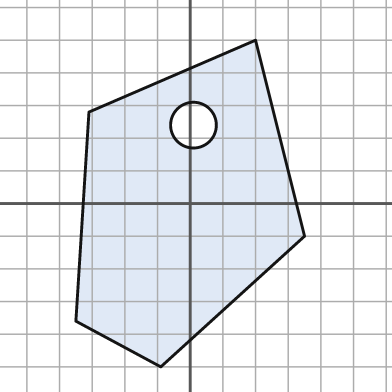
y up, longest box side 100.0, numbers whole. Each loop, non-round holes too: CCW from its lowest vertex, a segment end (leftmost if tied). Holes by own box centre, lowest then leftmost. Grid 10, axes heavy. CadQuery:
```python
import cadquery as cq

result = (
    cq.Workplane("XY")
    .moveTo(-9.0, -50.0)
    .lineTo(35.0, -10.0)
    .lineTo(20.0, 50.0)
    .lineTo(-31.0, 28.0)
    .lineTo(-35.0, -36.0)
    .close()
    .moveTo(1.0, 24.0)
    .circle(7.0)
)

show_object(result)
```